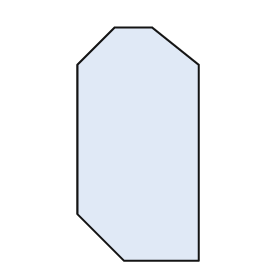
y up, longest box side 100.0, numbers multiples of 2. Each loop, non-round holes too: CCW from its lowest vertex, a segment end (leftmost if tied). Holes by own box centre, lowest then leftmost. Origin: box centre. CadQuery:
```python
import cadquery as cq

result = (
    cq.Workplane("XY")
    .moveTo(-6.0, -50.0)
    .lineTo(26.0, -50.0)
    .lineTo(26.0, 34.0)
    .lineTo(6.0, 50.0)
    .lineTo(-10.0, 50.0)
    .lineTo(-26.0, 34.0)
    .lineTo(-26.0, -30.0)
    .close()
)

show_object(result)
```